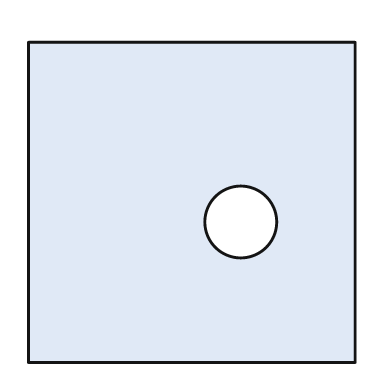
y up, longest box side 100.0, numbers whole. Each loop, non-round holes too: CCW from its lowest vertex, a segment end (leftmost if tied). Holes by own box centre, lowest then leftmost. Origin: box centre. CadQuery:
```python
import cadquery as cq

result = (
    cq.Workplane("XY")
    .moveTo(-50.0, -49.0)
    .lineTo(50.0, -49.0)
    .lineTo(50.0, 49.0)
    .lineTo(-50.0, 49.0)
    .close()
    .moveTo(15.0, -6.0)
    .circle(11.0)
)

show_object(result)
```